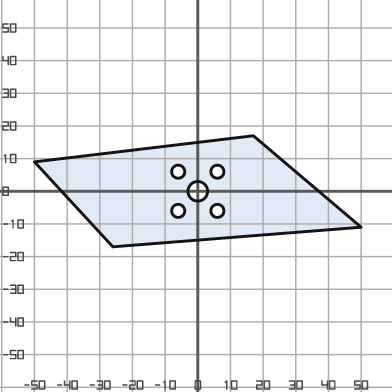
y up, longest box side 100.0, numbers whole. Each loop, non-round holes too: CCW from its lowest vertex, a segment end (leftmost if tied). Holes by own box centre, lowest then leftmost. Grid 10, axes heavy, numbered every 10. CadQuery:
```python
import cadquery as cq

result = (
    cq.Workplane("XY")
    .moveTo(-26.0, -17.0)
    .lineTo(50.0, -11.0)
    .lineTo(17.0, 17.0)
    .lineTo(-50.0, 9.0)
    .close()
    .moveTo(-6.0, -6.0)
    .circle(2.0)
    .moveTo(6.0, -6.0)
    .circle(2.0)
    .moveTo(0.0, 0.0)
    .circle(3.0)
    .moveTo(-6.0, 6.0)
    .circle(2.0)
    .moveTo(6.0, 6.0)
    .circle(2.0)
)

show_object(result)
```